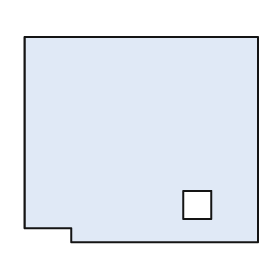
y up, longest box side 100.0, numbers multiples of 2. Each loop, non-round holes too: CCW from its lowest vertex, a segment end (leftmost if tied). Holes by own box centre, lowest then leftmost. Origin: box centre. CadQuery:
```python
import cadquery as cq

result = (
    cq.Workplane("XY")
    .moveTo(-30.0, -44.0)
    .lineTo(50.0, -44.0)
    .lineTo(50.0, 44.0)
    .lineTo(-50.0, 44.0)
    .lineTo(-50.0, -38.0)
    .lineTo(-30.0, -38.0)
    .close()
    .moveTo(18.0, -34.0)
    .lineTo(30.0, -34.0)
    .lineTo(30.0, -22.0)
    .lineTo(18.0, -22.0)
    .close()
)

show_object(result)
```